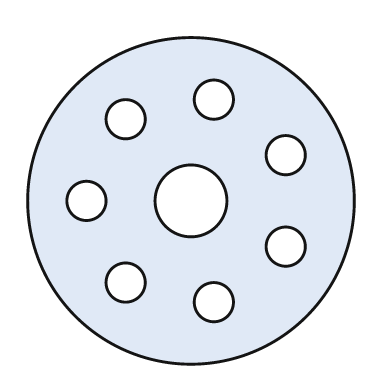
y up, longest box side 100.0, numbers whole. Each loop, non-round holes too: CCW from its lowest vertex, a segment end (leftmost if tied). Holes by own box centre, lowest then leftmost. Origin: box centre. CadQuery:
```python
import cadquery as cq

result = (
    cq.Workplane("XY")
    .moveTo(0.0, 0.0)
    .circle(50.0)
    .moveTo(7.0, -31.0)
    .circle(6.0)
    .moveTo(-20.0, -25.0)
    .circle(6.0)
    .moveTo(29.0, -14.0)
    .circle(6.0)
    .moveTo(-32.0, 0.0)
    .circle(6.0)
    .moveTo(0.0, 0.0)
    .circle(11.0)
    .moveTo(29.0, 14.0)
    .circle(6.0)
    .moveTo(-20.0, 25.0)
    .circle(6.0)
    .moveTo(7.0, 31.0)
    .circle(6.0)
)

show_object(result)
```